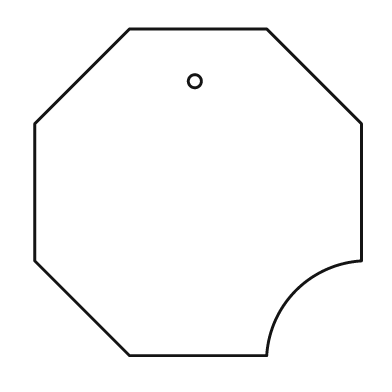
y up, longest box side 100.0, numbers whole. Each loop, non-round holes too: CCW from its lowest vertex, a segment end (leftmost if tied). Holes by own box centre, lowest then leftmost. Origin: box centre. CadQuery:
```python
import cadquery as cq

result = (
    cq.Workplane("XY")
    .moveTo(-21.0, -50.0)
    .lineTo(21.0, -50.0)
    .threePointArc((30.0, -30.0), (50.0, -21.0))
    .lineTo(50.0, 21.0)
    .lineTo(21.0, 50.0)
    .lineTo(-21.0, 50.0)
    .lineTo(-50.0, 21.0)
    .lineTo(-50.0, -21.0)
    .close()
    .moveTo(-1.0, 34.0)
    .circle(2.0)
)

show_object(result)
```